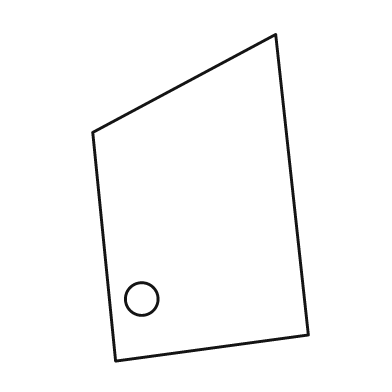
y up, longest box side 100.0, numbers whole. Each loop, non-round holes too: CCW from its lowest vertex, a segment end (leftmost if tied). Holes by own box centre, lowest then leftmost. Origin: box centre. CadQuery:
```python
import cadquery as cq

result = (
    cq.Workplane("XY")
    .moveTo(-26.0, -50.0)
    .lineTo(33.0, -42.0)
    .lineTo(23.0, 50.0)
    .lineTo(-33.0, 20.0)
    .close()
    .moveTo(-18.0, -31.0)
    .circle(5.0)
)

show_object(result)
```